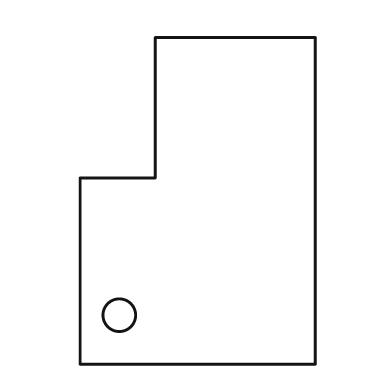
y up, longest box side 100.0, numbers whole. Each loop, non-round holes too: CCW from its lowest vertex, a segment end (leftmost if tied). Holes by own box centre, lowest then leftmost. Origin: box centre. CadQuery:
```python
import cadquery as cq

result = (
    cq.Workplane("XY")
    .moveTo(-36.0, -50.0)
    .lineTo(36.0, -50.0)
    .lineTo(36.0, 50.0)
    .lineTo(-13.0, 50.0)
    .lineTo(-13.0, 7.0)
    .lineTo(-36.0, 7.0)
    .close()
    .moveTo(-24.0, -35.0)
    .circle(5.0)
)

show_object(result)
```